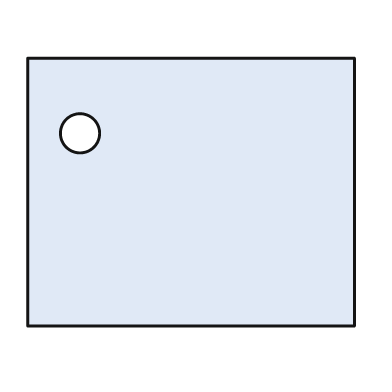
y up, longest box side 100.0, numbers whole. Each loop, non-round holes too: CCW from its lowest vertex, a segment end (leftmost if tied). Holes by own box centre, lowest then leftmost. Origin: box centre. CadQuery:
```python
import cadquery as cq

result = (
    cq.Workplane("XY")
    .moveTo(-50.0, -41.0)
    .lineTo(50.0, -41.0)
    .lineTo(50.0, 41.0)
    .lineTo(-50.0, 41.0)
    .close()
    .moveTo(-34.0, 18.0)
    .circle(6.0)
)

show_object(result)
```